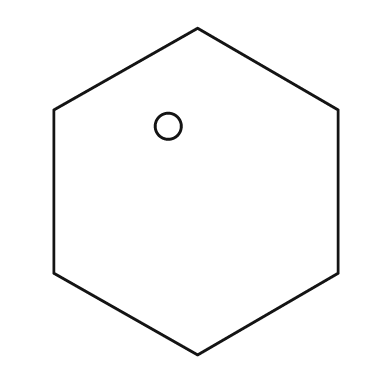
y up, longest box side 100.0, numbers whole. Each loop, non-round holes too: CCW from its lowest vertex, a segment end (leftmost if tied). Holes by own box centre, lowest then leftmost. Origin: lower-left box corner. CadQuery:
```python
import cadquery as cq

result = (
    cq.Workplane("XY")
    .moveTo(44.0, 0.0)
    .lineTo(87.0, 25.0)
    .lineTo(87.0, 75.0)
    .lineTo(44.0, 100.0)
    .lineTo(0.0, 75.0)
    .lineTo(0.0, 25.0)
    .close()
    .moveTo(35.0, 70.0)
    .circle(4.0)
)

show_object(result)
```